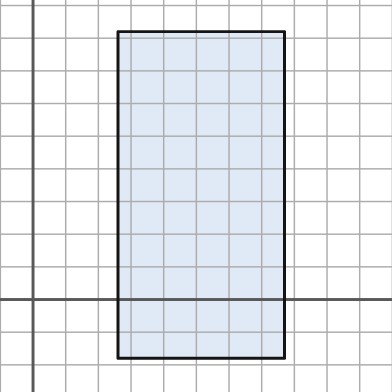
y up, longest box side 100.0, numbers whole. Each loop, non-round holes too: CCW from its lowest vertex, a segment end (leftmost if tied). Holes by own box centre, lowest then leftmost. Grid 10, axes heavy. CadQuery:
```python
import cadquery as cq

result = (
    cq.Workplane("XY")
    .moveTo(26.0, -18.0)
    .lineTo(77.0, -18.0)
    .lineTo(77.0, 82.0)
    .lineTo(26.0, 82.0)
    .close()
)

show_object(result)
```